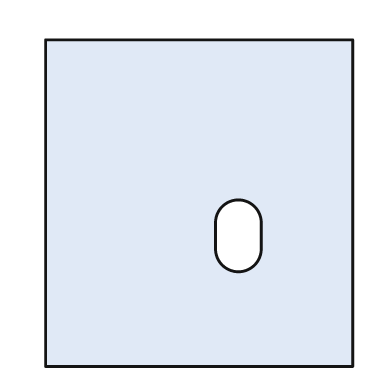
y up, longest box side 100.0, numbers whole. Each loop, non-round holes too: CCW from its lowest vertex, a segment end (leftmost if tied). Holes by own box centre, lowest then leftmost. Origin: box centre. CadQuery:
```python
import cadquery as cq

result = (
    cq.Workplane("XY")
    .moveTo(-47.0, -50.0)
    .lineTo(47.0, -50.0)
    .lineTo(47.0, 50.0)
    .lineTo(-47.0, 50.0)
    .close()
    .moveTo(5.0, -14.0)
    .threePointArc((12.0, -21.0), (19.0, -14.0))
    .lineTo(19.0, -6.0)
    .threePointArc((12.0, 1.0), (5.0, -6.0))
    .close()
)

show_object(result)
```